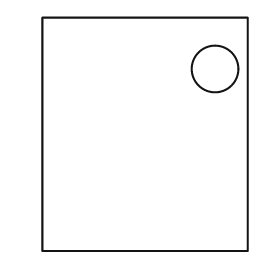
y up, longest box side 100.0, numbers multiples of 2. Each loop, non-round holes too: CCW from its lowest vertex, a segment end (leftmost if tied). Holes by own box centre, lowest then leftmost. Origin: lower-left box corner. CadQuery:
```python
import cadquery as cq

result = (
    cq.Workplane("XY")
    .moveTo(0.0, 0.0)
    .lineTo(88.0, 0.0)
    .lineTo(88.0, 100.0)
    .lineTo(0.0, 100.0)
    .close()
    .moveTo(74.0, 78.0)
    .circle(10.0)
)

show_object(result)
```